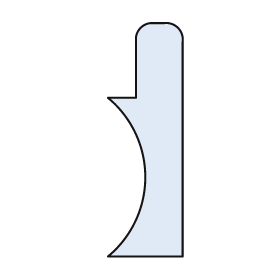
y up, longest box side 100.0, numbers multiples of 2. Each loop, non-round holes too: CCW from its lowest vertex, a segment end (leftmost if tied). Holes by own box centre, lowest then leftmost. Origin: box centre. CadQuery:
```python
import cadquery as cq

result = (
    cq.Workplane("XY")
    .moveTo(-16.0, -50.0)
    .lineTo(16.0, -50.0)
    .lineTo(16.0, 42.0)
    .threePointArc((14.0, 48.0), (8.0, 50.0))
    .lineTo(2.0, 50.0)
    .threePointArc((-2.0, 48.0), (-4.0, 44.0))
    .lineTo(-4.0, 18.0)
    .lineTo(-16.0, 18.0)
    .threePointArc((0.0, -16.0), (-16.0, -50.0))
    .close()
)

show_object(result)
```